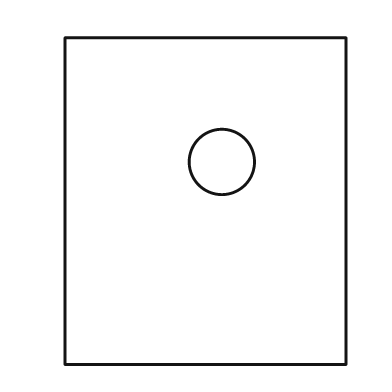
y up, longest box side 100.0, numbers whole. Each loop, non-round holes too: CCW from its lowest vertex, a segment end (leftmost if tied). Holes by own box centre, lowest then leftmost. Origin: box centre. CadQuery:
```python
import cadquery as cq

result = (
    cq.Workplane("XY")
    .moveTo(-43.0, -50.0)
    .lineTo(43.0, -50.0)
    .lineTo(43.0, 50.0)
    .lineTo(-43.0, 50.0)
    .close()
    .moveTo(5.0, 12.0)
    .circle(10.0)
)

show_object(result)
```